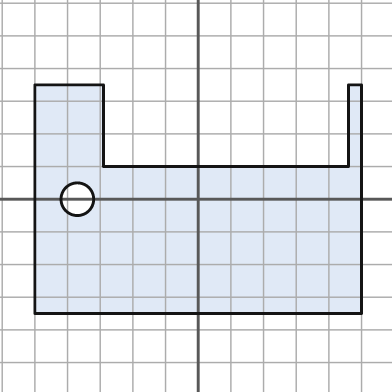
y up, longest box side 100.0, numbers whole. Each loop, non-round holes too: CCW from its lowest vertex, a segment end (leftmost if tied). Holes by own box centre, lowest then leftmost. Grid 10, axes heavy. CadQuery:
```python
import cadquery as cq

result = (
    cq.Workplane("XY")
    .moveTo(-50.0, -35.0)
    .lineTo(50.0, -35.0)
    .lineTo(50.0, 35.0)
    .lineTo(46.0, 35.0)
    .lineTo(46.0, 10.0)
    .lineTo(-29.0, 10.0)
    .lineTo(-29.0, 35.0)
    .lineTo(-50.0, 35.0)
    .close()
    .moveTo(-37.0, 0.0)
    .circle(5.0)
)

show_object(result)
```